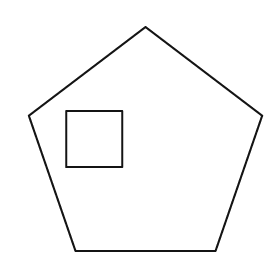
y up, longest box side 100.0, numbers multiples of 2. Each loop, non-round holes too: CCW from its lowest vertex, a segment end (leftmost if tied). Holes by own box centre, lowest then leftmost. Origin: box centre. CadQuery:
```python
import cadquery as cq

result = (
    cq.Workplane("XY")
    .moveTo(-30.0, -48.0)
    .lineTo(30.0, -48.0)
    .lineTo(50.0, 10.0)
    .lineTo(0.0, 48.0)
    .lineTo(-50.0, 10.0)
    .close()
    .moveTo(-34.0, -12.0)
    .lineTo(-10.0, -12.0)
    .lineTo(-10.0, 12.0)
    .lineTo(-34.0, 12.0)
    .close()
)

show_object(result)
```